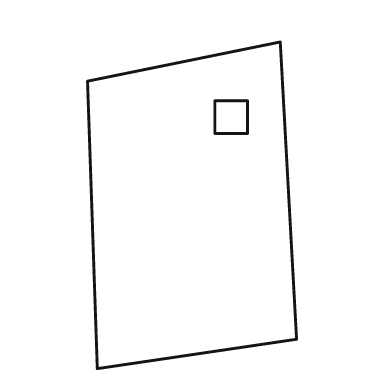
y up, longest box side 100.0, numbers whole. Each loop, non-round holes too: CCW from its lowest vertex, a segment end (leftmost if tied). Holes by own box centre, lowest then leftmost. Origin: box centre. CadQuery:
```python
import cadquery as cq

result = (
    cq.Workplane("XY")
    .moveTo(-29.0, -50.0)
    .lineTo(32.0, -41.0)
    .lineTo(27.0, 50.0)
    .lineTo(-32.0, 38.0)
    .close()
    .moveTo(7.0, 22.0)
    .lineTo(17.0, 22.0)
    .lineTo(17.0, 32.0)
    .lineTo(7.0, 32.0)
    .close()
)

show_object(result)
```